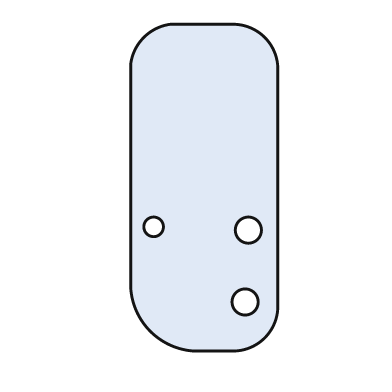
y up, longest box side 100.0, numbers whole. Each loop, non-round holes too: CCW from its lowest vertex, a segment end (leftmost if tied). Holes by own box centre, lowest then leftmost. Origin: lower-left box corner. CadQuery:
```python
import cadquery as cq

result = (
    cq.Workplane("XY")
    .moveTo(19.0, 0.0)
    .lineTo(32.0, 0.0)
    .threePointArc((41.0, 4.0), (45.0, 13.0))
    .lineTo(45.0, 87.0)
    .threePointArc((41.0, 96.0), (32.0, 100.0))
    .lineTo(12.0, 100.0)
    .threePointArc((4.0, 96.0), (0.0, 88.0))
    .lineTo(0.0, 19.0)
    .threePointArc((6.0, 6.0), (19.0, 0.0))
    .close()
    .moveTo(35.0, 15.0)
    .circle(4.0)
    .moveTo(36.0, 37.0)
    .circle(4.0)
    .moveTo(7.0, 38.0)
    .circle(3.0)
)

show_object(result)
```